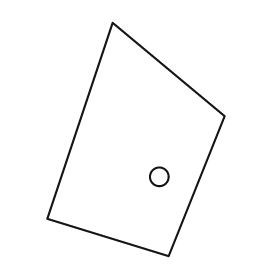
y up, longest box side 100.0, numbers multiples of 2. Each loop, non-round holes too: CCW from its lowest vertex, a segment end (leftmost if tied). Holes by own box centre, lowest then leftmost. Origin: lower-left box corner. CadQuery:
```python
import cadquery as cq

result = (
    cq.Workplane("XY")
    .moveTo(52.0, 0.0)
    .lineTo(76.0, 60.0)
    .lineTo(28.0, 100.0)
    .lineTo(0.0, 16.0)
    .close()
    .moveTo(48.0, 34.0)
    .circle(4.0)
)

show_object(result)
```